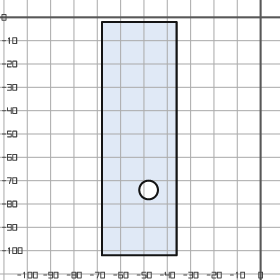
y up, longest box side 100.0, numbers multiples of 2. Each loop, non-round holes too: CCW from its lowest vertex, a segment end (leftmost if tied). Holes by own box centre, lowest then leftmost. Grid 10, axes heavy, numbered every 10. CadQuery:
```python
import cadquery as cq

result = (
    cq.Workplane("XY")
    .moveTo(-68.0, -102.0)
    .lineTo(-36.0, -102.0)
    .lineTo(-36.0, -2.0)
    .lineTo(-68.0, -2.0)
    .close()
    .moveTo(-48.0, -74.0)
    .circle(4.0)
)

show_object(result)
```